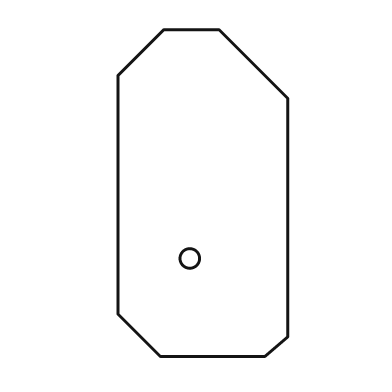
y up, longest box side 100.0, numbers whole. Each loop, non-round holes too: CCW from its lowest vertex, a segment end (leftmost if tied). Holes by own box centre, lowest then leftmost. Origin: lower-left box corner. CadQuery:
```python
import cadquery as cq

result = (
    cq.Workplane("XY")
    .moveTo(13.0, 0.0)
    .lineTo(45.0, 0.0)
    .lineTo(52.0, 6.0)
    .lineTo(52.0, 79.0)
    .lineTo(31.0, 100.0)
    .lineTo(14.0, 100.0)
    .lineTo(0.0, 86.0)
    .lineTo(0.0, 13.0)
    .close()
    .moveTo(22.0, 30.0)
    .circle(3.0)
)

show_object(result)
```